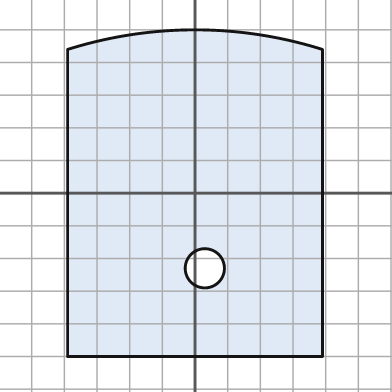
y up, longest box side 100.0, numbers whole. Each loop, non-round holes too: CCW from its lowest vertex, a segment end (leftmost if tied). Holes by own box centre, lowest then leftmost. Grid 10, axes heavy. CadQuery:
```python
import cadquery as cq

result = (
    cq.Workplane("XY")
    .moveTo(-39.0, -50.0)
    .lineTo(39.0, -50.0)
    .lineTo(39.0, 44.0)
    .threePointArc((0.0, 50.0), (-39.0, 44.0))
    .close()
    .moveTo(3.0, -23.0)
    .circle(6.0)
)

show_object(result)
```